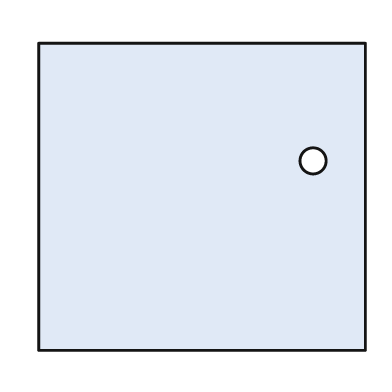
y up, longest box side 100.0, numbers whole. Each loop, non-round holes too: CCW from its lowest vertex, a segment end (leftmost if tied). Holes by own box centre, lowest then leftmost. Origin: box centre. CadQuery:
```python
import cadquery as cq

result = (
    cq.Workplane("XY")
    .moveTo(-50.0, -47.0)
    .lineTo(50.0, -47.0)
    .lineTo(50.0, 47.0)
    .lineTo(-50.0, 47.0)
    .close()
    .moveTo(34.0, 11.0)
    .circle(4.0)
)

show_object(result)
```